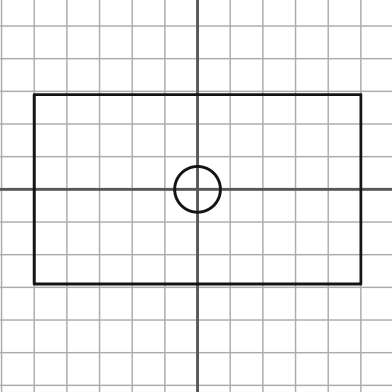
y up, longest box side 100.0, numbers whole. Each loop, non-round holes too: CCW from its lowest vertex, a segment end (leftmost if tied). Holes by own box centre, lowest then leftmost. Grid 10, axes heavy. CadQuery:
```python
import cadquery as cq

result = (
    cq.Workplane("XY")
    .moveTo(-50.0, -29.0)
    .lineTo(50.0, -29.0)
    .lineTo(50.0, 29.0)
    .lineTo(-50.0, 29.0)
    .close()
    .moveTo(0.0, 0.0)
    .circle(7.0)
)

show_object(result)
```